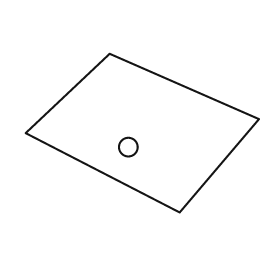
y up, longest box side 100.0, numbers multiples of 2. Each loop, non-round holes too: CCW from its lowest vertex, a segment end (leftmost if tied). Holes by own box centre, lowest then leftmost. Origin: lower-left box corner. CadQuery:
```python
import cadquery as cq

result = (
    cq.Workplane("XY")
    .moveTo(66.0, 0.0)
    .lineTo(100.0, 40.0)
    .lineTo(36.0, 68.0)
    .lineTo(0.0, 34.0)
    .close()
    .moveTo(44.0, 28.0)
    .circle(4.0)
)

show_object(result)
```